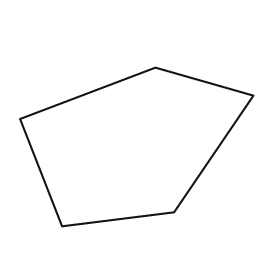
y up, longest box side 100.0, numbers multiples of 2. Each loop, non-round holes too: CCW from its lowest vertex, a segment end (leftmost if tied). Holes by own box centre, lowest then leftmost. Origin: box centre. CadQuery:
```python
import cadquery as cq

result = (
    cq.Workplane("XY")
    .moveTo(-32.0, -34.0)
    .lineTo(16.0, -28.0)
    .lineTo(50.0, 22.0)
    .lineTo(8.0, 34.0)
    .lineTo(-50.0, 12.0)
    .close()
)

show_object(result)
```